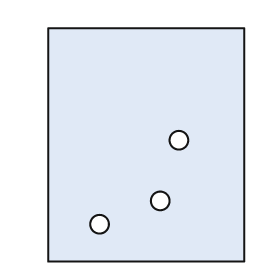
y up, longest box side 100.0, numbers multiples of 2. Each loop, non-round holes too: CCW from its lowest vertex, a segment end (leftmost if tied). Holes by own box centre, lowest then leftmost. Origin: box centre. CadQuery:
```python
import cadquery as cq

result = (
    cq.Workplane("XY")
    .moveTo(-42.0, -50.0)
    .lineTo(42.0, -50.0)
    .lineTo(42.0, 50.0)
    .lineTo(-42.0, 50.0)
    .close()
    .moveTo(-20.0, -34.0)
    .circle(4.0)
    .moveTo(6.0, -24.0)
    .circle(4.0)
    .moveTo(14.0, 2.0)
    .circle(4.0)
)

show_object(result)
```